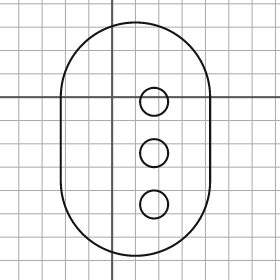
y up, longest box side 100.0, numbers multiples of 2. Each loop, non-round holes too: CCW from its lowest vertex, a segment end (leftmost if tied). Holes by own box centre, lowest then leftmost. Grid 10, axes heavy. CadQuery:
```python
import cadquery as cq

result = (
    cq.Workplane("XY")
    .moveTo(-22.0, -36.0)
    .threePointArc((10.0, -68.0), (42.0, -36.0))
    .lineTo(42.0, 0.0)
    .threePointArc((10.0, 32.0), (-22.0, 0.0))
    .close()
    .moveTo(18.0, -46.0)
    .circle(6.0)
    .moveTo(18.0, -24.0)
    .circle(6.0)
    .moveTo(18.0, -2.0)
    .circle(6.0)
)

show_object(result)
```